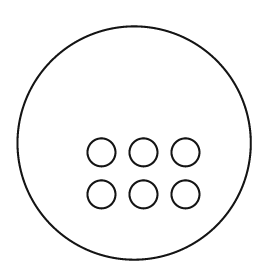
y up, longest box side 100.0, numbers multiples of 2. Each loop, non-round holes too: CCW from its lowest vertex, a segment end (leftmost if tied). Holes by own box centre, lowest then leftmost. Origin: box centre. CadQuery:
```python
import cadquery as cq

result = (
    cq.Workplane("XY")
    .moveTo(0.0, 0.0)
    .circle(50.0)
    .moveTo(-14.0, -22.0)
    .circle(6.0)
    .moveTo(4.0, -22.0)
    .circle(6.0)
    .moveTo(22.0, -22.0)
    .circle(6.0)
    .moveTo(-14.0, -4.0)
    .circle(6.0)
    .moveTo(4.0, -4.0)
    .circle(6.0)
    .moveTo(22.0, -4.0)
    .circle(6.0)
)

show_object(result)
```